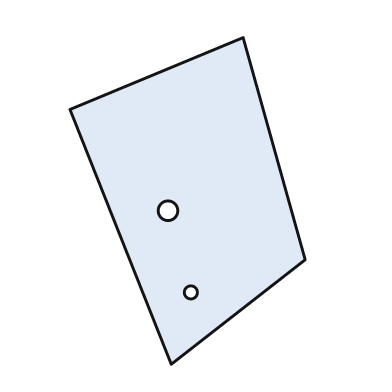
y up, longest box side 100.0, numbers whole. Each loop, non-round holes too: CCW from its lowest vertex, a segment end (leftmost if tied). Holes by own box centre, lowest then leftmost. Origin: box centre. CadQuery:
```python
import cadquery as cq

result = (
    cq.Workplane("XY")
    .moveTo(-5.0, -50.0)
    .lineTo(36.0, -18.0)
    .lineTo(17.0, 50.0)
    .lineTo(-36.0, 28.0)
    .close()
    .moveTo(1.0, -28.0)
    .circle(2.0)
    .moveTo(-6.0, -3.0)
    .circle(3.0)
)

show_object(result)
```